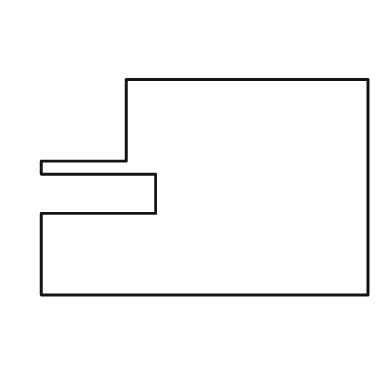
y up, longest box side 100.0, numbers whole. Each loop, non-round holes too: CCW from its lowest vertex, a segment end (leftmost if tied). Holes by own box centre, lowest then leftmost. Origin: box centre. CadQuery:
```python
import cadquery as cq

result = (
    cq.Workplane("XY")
    .moveTo(-50.0, -33.0)
    .lineTo(50.0, -33.0)
    .lineTo(50.0, 33.0)
    .lineTo(-24.0, 33.0)
    .lineTo(-24.0, 8.0)
    .lineTo(-50.0, 8.0)
    .lineTo(-50.0, 4.0)
    .lineTo(-15.0, 4.0)
    .lineTo(-15.0, -8.0)
    .lineTo(-50.0, -8.0)
    .close()
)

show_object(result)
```